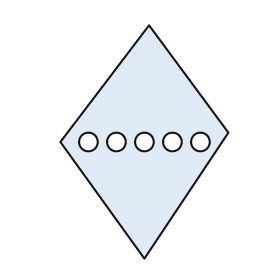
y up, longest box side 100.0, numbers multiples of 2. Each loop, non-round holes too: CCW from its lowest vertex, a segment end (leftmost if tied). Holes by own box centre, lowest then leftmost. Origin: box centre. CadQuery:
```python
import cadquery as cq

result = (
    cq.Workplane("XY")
    .moveTo(0.0, -50.0)
    .lineTo(36.0, 4.0)
    .lineTo(2.0, 50.0)
    .lineTo(-36.0, 0.0)
    .close()
    .moveTo(-24.0, 0.0)
    .circle(4.0)
    .moveTo(-12.0, 0.0)
    .circle(4.0)
    .moveTo(0.0, 0.0)
    .circle(4.0)
    .moveTo(12.0, 0.0)
    .circle(4.0)
    .moveTo(24.0, 0.0)
    .circle(4.0)
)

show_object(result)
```